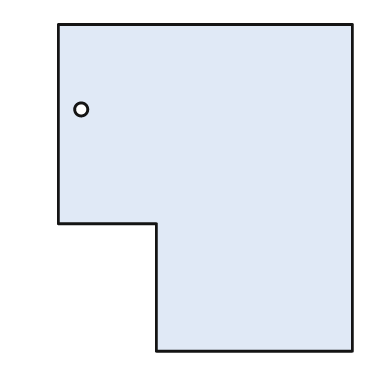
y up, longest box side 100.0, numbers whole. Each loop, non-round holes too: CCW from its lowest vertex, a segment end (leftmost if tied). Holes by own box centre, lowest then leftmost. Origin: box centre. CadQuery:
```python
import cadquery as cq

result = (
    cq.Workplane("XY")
    .moveTo(-15.0, -50.0)
    .lineTo(45.0, -50.0)
    .lineTo(45.0, 50.0)
    .lineTo(-45.0, 50.0)
    .lineTo(-45.0, -11.0)
    .lineTo(-15.0, -11.0)
    .close()
    .moveTo(-38.0, 24.0)
    .circle(2.0)
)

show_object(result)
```